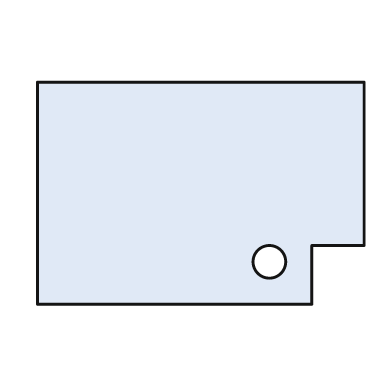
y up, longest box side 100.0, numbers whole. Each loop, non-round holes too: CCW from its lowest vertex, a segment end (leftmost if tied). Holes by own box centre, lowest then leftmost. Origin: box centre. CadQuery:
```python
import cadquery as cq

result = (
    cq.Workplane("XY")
    .moveTo(-50.0, -34.0)
    .lineTo(34.0, -34.0)
    .lineTo(34.0, -16.0)
    .lineTo(50.0, -16.0)
    .lineTo(50.0, 34.0)
    .lineTo(-50.0, 34.0)
    .close()
    .moveTo(21.0, -21.0)
    .circle(5.0)
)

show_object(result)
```